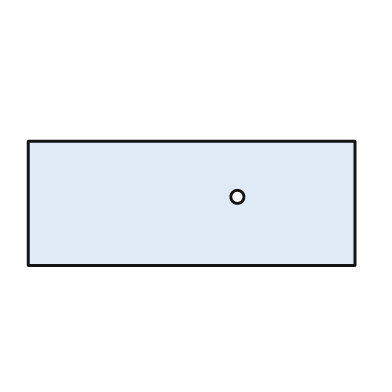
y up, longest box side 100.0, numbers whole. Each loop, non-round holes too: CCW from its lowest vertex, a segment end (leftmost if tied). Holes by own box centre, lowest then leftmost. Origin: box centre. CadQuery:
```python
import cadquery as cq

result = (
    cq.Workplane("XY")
    .moveTo(-50.0, -19.0)
    .lineTo(50.0, -19.0)
    .lineTo(50.0, 19.0)
    .lineTo(-50.0, 19.0)
    .close()
    .moveTo(14.0, 2.0)
    .circle(2.0)
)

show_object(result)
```